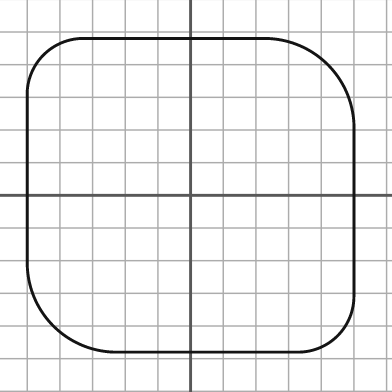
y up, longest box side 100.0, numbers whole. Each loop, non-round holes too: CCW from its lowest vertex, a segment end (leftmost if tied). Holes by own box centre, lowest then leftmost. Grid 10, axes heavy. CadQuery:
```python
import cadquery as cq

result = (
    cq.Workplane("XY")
    .moveTo(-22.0, -48.0)
    .lineTo(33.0, -48.0)
    .threePointArc((45.0, -43.0), (50.0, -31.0))
    .lineTo(50.0, 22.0)
    .threePointArc((42.0, 40.0), (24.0, 48.0))
    .lineTo(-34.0, 48.0)
    .threePointArc((-45.0, 43.0), (-50.0, 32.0))
    .lineTo(-50.0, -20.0)
    .threePointArc((-42.0, -40.0), (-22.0, -48.0))
    .close()
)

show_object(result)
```